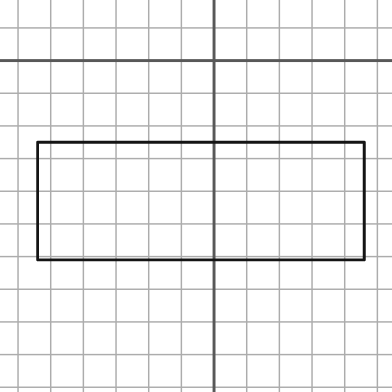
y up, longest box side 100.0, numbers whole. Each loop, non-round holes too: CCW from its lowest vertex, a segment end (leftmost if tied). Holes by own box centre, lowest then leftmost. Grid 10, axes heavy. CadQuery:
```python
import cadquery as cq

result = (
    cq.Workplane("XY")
    .moveTo(-54.0, -61.0)
    .lineTo(46.0, -61.0)
    .lineTo(46.0, -25.0)
    .lineTo(-54.0, -25.0)
    .close()
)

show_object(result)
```